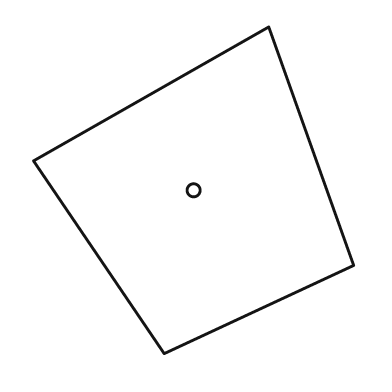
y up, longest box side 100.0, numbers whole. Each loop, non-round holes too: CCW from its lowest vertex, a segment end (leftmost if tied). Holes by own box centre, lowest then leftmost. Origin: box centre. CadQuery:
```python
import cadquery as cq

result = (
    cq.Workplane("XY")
    .moveTo(-9.0, -50.0)
    .lineTo(49.0, -23.0)
    .lineTo(23.0, 50.0)
    .lineTo(-49.0, 9.0)
    .close()
    .moveTo(0.0, 0.0)
    .circle(2.0)
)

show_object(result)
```